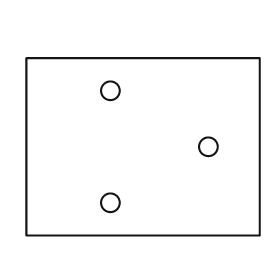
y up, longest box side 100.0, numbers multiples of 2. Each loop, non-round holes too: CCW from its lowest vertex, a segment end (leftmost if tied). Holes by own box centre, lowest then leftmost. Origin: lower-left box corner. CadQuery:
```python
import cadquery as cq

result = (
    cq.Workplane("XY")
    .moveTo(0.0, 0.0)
    .lineTo(100.0, 0.0)
    .lineTo(100.0, 76.0)
    .lineTo(0.0, 76.0)
    .close()
    .moveTo(36.0, 14.0)
    .circle(4.0)
    .moveTo(78.0, 38.0)
    .circle(4.0)
    .moveTo(36.0, 62.0)
    .circle(4.0)
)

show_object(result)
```